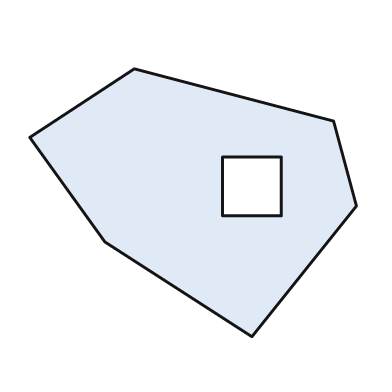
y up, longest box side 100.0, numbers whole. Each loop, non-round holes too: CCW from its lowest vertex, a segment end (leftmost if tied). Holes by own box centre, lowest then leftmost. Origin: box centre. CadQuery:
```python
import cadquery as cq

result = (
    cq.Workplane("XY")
    .moveTo(18.0, -41.0)
    .lineTo(50.0, -1.0)
    .lineTo(43.0, 25.0)
    .lineTo(-18.0, 41.0)
    .lineTo(-50.0, 20.0)
    .lineTo(-27.0, -12.0)
    .close()
    .moveTo(9.0, -4.0)
    .lineTo(27.0, -4.0)
    .lineTo(27.0, 14.0)
    .lineTo(9.0, 14.0)
    .close()
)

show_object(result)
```